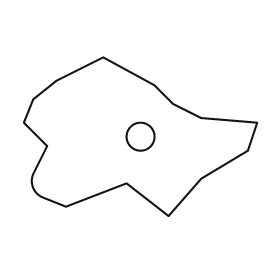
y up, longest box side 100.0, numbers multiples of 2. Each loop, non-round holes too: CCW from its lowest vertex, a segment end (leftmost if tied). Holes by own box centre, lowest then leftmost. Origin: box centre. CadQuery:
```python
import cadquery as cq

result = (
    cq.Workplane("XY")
    .moveTo(12.0, -34.0)
    .lineTo(26.0, -18.0)
    .lineTo(46.0, -6.0)
    .lineTo(50.0, 6.0)
    .lineTo(26.0, 8.0)
    .lineTo(14.0, 14.0)
    .lineTo(6.0, 22.0)
    .lineTo(-16.0, 34.0)
    .lineTo(-36.0, 24.0)
    .lineTo(-46.0, 16.0)
    .lineTo(-50.0, 6.0)
    .lineTo(-40.0, -4.0)
    .lineTo(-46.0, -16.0)
    .threePointArc((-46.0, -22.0), (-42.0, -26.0))
    .lineTo(-32.0, -30.0)
    .lineTo(-6.0, -20.0)
    .close()
    .moveTo(0.0, 0.0)
    .circle(6.0)
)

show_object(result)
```